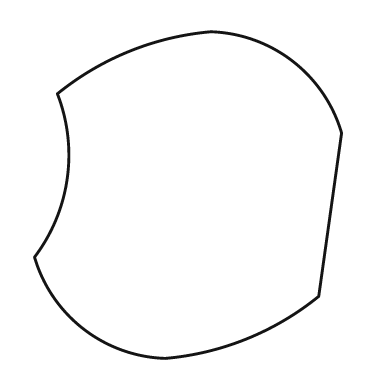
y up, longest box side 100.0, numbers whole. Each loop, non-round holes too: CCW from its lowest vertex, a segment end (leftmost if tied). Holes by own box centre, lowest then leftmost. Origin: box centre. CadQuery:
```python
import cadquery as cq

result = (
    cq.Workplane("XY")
    .moveTo(-7.0, -50.0)
    .threePointArc((18.0, -44.0), (40.0, -31.0))
    .lineTo(47.0, 19.0)
    .threePointArc((32.0, 41.0), (7.0, 50.0))
    .threePointArc((-18.0, 44.0), (-40.0, 31.0))
    .threePointArc((-37.0, 5.0), (-47.0, -19.0))
    .threePointArc((-32.0, -41.0), (-7.0, -50.0))
    .close()
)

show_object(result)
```